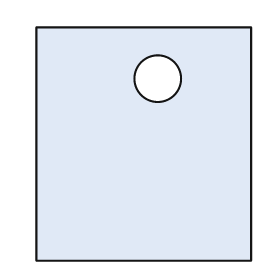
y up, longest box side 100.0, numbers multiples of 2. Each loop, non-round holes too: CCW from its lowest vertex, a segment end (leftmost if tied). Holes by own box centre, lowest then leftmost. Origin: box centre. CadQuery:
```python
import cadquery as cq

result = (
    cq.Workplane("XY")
    .moveTo(-46.0, -50.0)
    .lineTo(46.0, -50.0)
    .lineTo(46.0, 50.0)
    .lineTo(-46.0, 50.0)
    .close()
    .moveTo(6.0, 28.0)
    .circle(10.0)
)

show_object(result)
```